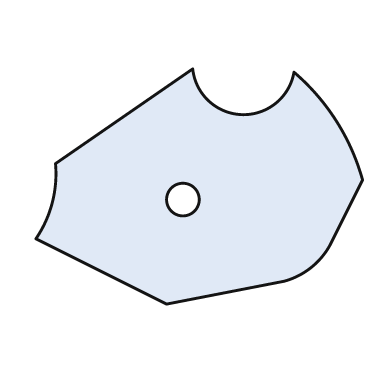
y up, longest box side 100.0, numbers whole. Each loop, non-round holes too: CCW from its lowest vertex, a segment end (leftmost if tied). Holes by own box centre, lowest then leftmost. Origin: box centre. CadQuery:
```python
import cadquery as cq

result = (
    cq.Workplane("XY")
    .moveTo(-10.0, -36.0)
    .lineTo(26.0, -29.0)
    .threePointArc((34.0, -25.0), (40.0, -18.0))
    .lineTo(50.0, 2.0)
    .threePointArc((42.0, 20.0), (29.0, 35.0))
    .threePointArc((13.0, 22.0), (-2.0, 36.0))
    .lineTo(-44.0, 7.0)
    .threePointArc((-45.0, -5.0), (-50.0, -16.0))
    .close()
    .moveTo(-5.0, -4.0)
    .circle(5.0)
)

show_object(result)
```